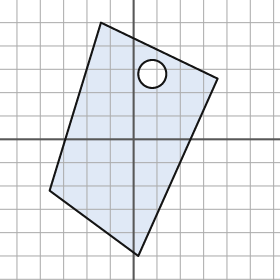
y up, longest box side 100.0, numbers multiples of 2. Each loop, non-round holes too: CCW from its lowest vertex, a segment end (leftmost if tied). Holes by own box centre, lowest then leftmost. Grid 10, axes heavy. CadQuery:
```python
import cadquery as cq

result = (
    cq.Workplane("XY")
    .moveTo(2.0, -50.0)
    .lineTo(36.0, 26.0)
    .lineTo(-14.0, 50.0)
    .lineTo(-36.0, -22.0)
    .close()
    .moveTo(8.0, 28.0)
    .circle(6.0)
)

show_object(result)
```